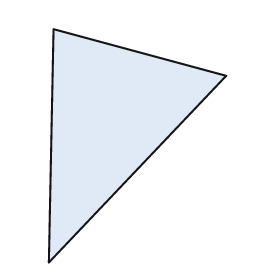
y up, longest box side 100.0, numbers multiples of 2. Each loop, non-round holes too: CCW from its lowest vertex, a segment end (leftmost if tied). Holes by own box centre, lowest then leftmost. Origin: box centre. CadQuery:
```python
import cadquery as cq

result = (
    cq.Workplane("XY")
    .moveTo(-38.0, -50.0)
    .lineTo(38.0, 30.0)
    .lineTo(-36.0, 50.0)
    .close()
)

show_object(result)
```